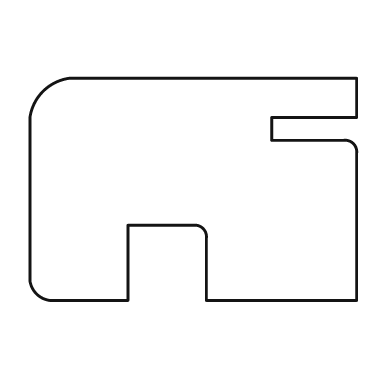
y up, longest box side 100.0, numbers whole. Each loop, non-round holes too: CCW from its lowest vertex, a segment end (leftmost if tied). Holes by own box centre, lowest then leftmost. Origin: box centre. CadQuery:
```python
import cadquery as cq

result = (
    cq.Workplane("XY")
    .moveTo(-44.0, -34.0)
    .lineTo(-20.0, -34.0)
    .lineTo(-20.0, -11.0)
    .lineTo(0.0, -11.0)
    .threePointArc((3.0, -12.0), (4.0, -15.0))
    .lineTo(4.0, -34.0)
    .lineTo(50.0, -34.0)
    .lineTo(50.0, 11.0)
    .threePointArc((49.0, 14.0), (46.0, 15.0))
    .lineTo(24.0, 15.0)
    .lineTo(24.0, 22.0)
    .lineTo(50.0, 22.0)
    .lineTo(50.0, 34.0)
    .lineTo(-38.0, 34.0)
    .threePointArc((-46.0, 30.0), (-50.0, 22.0))
    .lineTo(-50.0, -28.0)
    .threePointArc((-48.0, -32.0), (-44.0, -34.0))
    .close()
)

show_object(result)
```